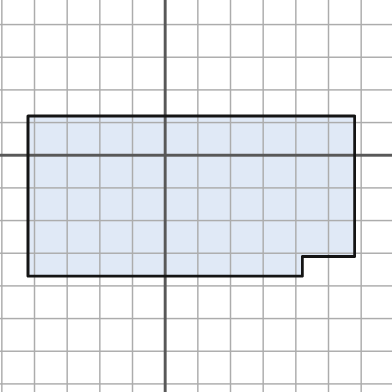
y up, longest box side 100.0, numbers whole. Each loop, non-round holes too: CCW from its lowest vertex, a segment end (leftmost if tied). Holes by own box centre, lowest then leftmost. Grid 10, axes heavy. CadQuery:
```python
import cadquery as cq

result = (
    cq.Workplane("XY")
    .moveTo(-42.0, -37.0)
    .lineTo(42.0, -37.0)
    .lineTo(42.0, -31.0)
    .lineTo(58.0, -31.0)
    .lineTo(58.0, 12.0)
    .lineTo(-42.0, 12.0)
    .close()
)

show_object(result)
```